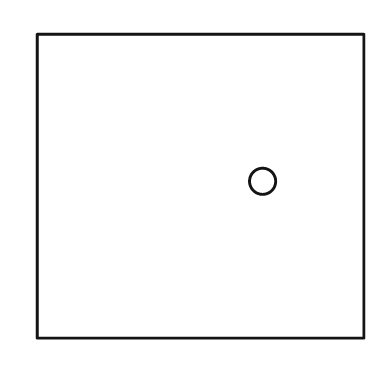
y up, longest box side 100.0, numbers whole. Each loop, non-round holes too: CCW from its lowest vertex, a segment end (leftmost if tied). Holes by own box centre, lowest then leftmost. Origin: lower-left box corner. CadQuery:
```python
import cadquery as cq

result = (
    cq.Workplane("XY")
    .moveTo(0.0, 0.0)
    .lineTo(100.0, 0.0)
    .lineTo(100.0, 93.0)
    .lineTo(0.0, 93.0)
    .close()
    .moveTo(69.0, 48.0)
    .circle(4.0)
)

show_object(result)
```